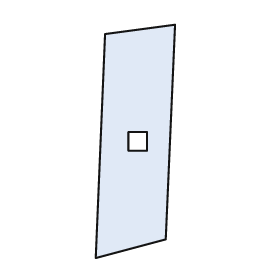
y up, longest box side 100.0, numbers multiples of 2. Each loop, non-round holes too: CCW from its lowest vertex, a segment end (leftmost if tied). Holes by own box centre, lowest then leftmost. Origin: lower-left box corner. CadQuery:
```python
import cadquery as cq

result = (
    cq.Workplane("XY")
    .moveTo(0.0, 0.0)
    .lineTo(30.0, 8.0)
    .lineTo(34.0, 100.0)
    .lineTo(4.0, 96.0)
    .close()
    .moveTo(14.0, 46.0)
    .lineTo(22.0, 46.0)
    .lineTo(22.0, 54.0)
    .lineTo(14.0, 54.0)
    .close()
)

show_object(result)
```